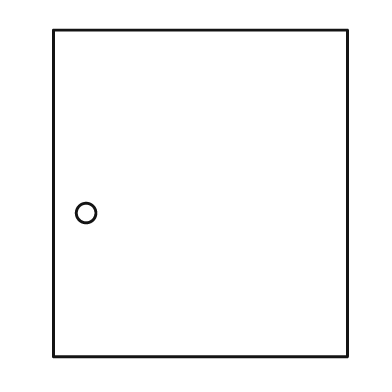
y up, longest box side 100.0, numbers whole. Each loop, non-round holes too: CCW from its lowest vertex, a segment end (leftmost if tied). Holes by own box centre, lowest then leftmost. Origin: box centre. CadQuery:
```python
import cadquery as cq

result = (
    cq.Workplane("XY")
    .moveTo(-45.0, -50.0)
    .lineTo(45.0, -50.0)
    .lineTo(45.0, 50.0)
    .lineTo(-45.0, 50.0)
    .close()
    .moveTo(-35.0, -6.0)
    .circle(3.0)
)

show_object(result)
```